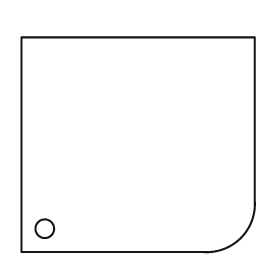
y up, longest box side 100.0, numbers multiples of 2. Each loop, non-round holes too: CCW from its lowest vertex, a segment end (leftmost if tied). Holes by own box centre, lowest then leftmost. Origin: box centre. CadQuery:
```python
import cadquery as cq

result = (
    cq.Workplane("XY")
    .moveTo(-50.0, -46.0)
    .lineTo(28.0, -46.0)
    .threePointArc((44.0, -40.0), (50.0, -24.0))
    .lineTo(50.0, 46.0)
    .lineTo(-50.0, 46.0)
    .close()
    .moveTo(-40.0, -36.0)
    .circle(4.0)
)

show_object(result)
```